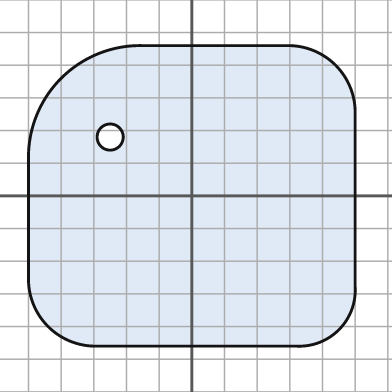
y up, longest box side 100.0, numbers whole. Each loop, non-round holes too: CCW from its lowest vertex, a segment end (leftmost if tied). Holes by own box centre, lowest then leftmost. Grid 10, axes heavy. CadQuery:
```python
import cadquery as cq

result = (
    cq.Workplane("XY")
    .moveTo(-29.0, -46.0)
    .lineTo(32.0, -46.0)
    .threePointArc((45.0, -41.0), (50.0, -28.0))
    .lineTo(50.0, 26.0)
    .threePointArc((44.0, 40.0), (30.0, 46.0))
    .lineTo(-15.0, 46.0)
    .threePointArc((-40.0, 36.0), (-50.0, 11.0))
    .lineTo(-50.0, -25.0)
    .threePointArc((-44.0, -40.0), (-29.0, -46.0))
    .close()
    .moveTo(-25.0, 18.0)
    .circle(4.0)
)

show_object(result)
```